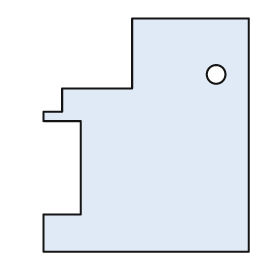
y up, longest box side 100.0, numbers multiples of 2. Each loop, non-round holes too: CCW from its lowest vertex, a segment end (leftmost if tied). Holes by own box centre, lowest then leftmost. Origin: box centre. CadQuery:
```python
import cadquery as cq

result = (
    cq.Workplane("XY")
    .moveTo(-44.0, -50.0)
    .lineTo(44.0, -50.0)
    .lineTo(44.0, 50.0)
    .lineTo(-6.0, 50.0)
    .lineTo(-6.0, 20.0)
    .lineTo(-36.0, 20.0)
    .lineTo(-36.0, 10.0)
    .lineTo(-44.0, 10.0)
    .lineTo(-44.0, 6.0)
    .lineTo(-28.0, 6.0)
    .lineTo(-28.0, -34.0)
    .lineTo(-44.0, -34.0)
    .close()
    .moveTo(30.0, 26.0)
    .circle(4.0)
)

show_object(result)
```